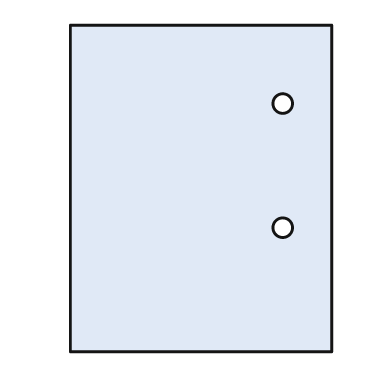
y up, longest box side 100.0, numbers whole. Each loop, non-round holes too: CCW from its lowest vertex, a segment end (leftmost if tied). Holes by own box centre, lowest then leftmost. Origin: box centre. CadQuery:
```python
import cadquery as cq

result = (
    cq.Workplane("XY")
    .moveTo(-40.0, -50.0)
    .lineTo(40.0, -50.0)
    .lineTo(40.0, 50.0)
    .lineTo(-40.0, 50.0)
    .close()
    .moveTo(25.0, -12.0)
    .circle(3.0)
    .moveTo(25.0, 26.0)
    .circle(3.0)
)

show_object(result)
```